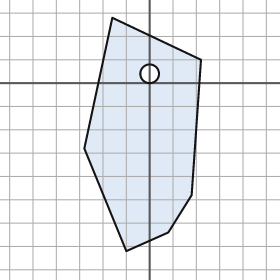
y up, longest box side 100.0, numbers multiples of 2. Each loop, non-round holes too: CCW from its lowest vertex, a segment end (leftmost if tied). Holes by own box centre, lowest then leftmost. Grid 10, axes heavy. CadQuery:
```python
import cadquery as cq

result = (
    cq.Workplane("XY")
    .moveTo(-10.0, -72.0)
    .lineTo(8.0, -64.0)
    .lineTo(18.0, -48.0)
    .lineTo(22.0, 10.0)
    .lineTo(-16.0, 28.0)
    .lineTo(-28.0, -28.0)
    .close()
    .moveTo(0.0, 4.0)
    .circle(4.0)
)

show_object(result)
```